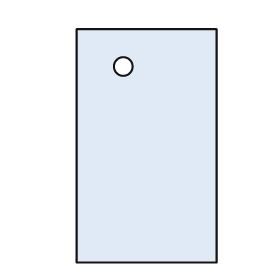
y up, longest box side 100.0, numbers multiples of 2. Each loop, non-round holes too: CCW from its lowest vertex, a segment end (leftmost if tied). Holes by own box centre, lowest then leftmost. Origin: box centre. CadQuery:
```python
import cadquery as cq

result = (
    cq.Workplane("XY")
    .moveTo(-30.0, -50.0)
    .lineTo(30.0, -50.0)
    .lineTo(30.0, 50.0)
    .lineTo(-30.0, 50.0)
    .close()
    .moveTo(-10.0, 34.0)
    .circle(4.0)
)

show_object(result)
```